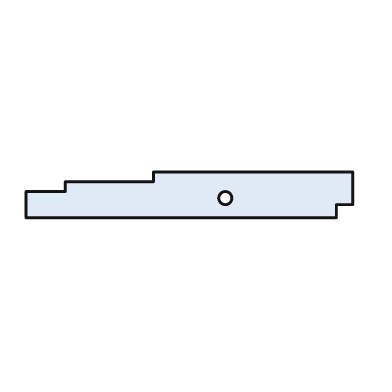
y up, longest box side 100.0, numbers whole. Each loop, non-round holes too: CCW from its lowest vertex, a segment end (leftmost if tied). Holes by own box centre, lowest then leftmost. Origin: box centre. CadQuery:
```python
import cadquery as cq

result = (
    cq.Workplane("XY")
    .moveTo(-50.0, -7.0)
    .lineTo(45.0, -7.0)
    .lineTo(45.0, -3.0)
    .lineTo(50.0, -3.0)
    .lineTo(50.0, 7.0)
    .lineTo(-11.0, 7.0)
    .lineTo(-11.0, 4.0)
    .lineTo(-38.0, 4.0)
    .lineTo(-38.0, 1.0)
    .lineTo(-50.0, 1.0)
    .close()
    .moveTo(11.0, -1.0)
    .circle(2.0)
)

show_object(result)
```